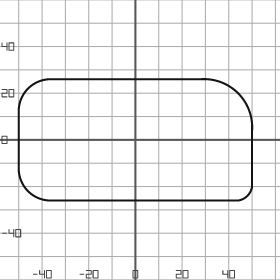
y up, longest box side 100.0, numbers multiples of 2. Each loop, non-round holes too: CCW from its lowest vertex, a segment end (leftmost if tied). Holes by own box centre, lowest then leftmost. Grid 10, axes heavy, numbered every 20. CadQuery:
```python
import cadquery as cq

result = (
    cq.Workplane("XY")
    .moveTo(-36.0, -26.0)
    .lineTo(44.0, -26.0)
    .threePointArc((48.0, -24.0), (50.0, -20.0))
    .lineTo(50.0, 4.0)
    .threePointArc((44.0, 20.0), (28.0, 26.0))
    .lineTo(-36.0, 26.0)
    .threePointArc((-46.0, 22.0), (-50.0, 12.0))
    .lineTo(-50.0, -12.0)
    .threePointArc((-46.0, -22.0), (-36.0, -26.0))
    .close()
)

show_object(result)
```